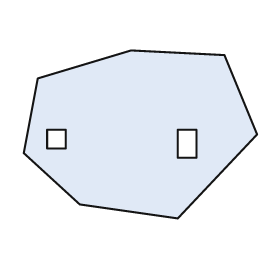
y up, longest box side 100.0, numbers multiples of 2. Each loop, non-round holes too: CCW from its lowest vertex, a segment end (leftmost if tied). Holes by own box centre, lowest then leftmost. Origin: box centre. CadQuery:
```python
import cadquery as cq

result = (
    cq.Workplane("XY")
    .moveTo(16.0, -36.0)
    .lineTo(50.0, 0.0)
    .lineTo(36.0, 34.0)
    .lineTo(-4.0, 36.0)
    .lineTo(-44.0, 24.0)
    .lineTo(-50.0, -8.0)
    .lineTo(-26.0, -30.0)
    .close()
    .moveTo(16.0, -10.0)
    .lineTo(24.0, -10.0)
    .lineTo(24.0, 2.0)
    .lineTo(16.0, 2.0)
    .close()
    .moveTo(-40.0, -6.0)
    .lineTo(-32.0, -6.0)
    .lineTo(-32.0, 2.0)
    .lineTo(-40.0, 2.0)
    .close()
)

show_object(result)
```